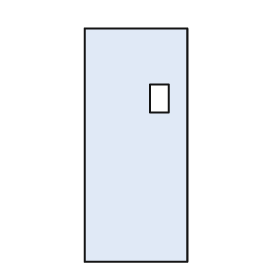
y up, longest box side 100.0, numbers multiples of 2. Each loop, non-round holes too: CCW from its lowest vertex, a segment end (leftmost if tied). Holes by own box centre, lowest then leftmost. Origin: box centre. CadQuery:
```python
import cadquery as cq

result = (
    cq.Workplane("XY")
    .moveTo(-22.0, -50.0)
    .lineTo(22.0, -50.0)
    .lineTo(22.0, 50.0)
    .lineTo(-22.0, 50.0)
    .close()
    .moveTo(6.0, 14.0)
    .lineTo(14.0, 14.0)
    .lineTo(14.0, 26.0)
    .lineTo(6.0, 26.0)
    .close()
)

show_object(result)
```